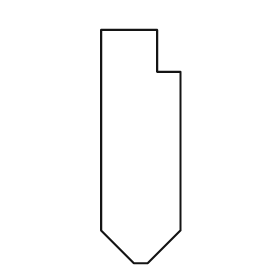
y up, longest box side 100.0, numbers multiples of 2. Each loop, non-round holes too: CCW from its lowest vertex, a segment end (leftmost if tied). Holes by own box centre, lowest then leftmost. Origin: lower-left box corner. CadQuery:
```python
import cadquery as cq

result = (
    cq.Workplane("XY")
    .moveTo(14.0, 0.0)
    .lineTo(20.0, 0.0)
    .lineTo(34.0, 14.0)
    .lineTo(34.0, 82.0)
    .lineTo(24.0, 82.0)
    .lineTo(24.0, 100.0)
    .lineTo(0.0, 100.0)
    .lineTo(0.0, 14.0)
    .close()
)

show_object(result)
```